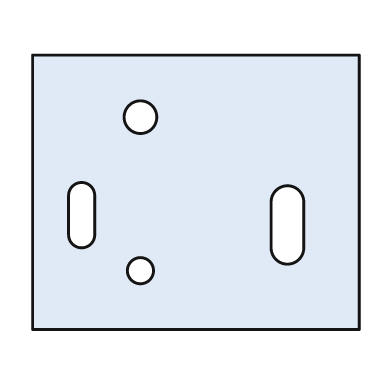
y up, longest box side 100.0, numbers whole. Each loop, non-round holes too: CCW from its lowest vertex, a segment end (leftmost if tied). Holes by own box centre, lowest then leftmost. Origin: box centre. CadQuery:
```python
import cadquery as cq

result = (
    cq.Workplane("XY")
    .moveTo(-50.0, -42.0)
    .lineTo(50.0, -42.0)
    .lineTo(50.0, 42.0)
    .lineTo(-50.0, 42.0)
    .close()
    .moveTo(-17.0, -24.0)
    .circle(4.0)
    .moveTo(23.0, -17.0)
    .threePointArc((28.0, -22.0), (33.0, -17.0))
    .lineTo(33.0, -3.0)
    .threePointArc((28.0, 2.0), (23.0, -3.0))
    .close()
    .moveTo(-39.0, -13.0)
    .threePointArc((-35.0, -17.0), (-31.0, -13.0))
    .lineTo(-31.0, -1.0)
    .threePointArc((-35.0, 3.0), (-39.0, -1.0))
    .close()
    .moveTo(-17.0, 23.0)
    .circle(5.0)
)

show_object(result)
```